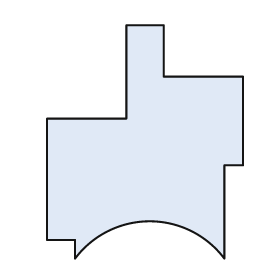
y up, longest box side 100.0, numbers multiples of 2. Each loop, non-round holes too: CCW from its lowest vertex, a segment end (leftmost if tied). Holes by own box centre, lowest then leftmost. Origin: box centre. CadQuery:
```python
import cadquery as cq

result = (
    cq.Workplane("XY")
    .moveTo(-30.0, -50.0)
    .threePointArc((2.0, -34.0), (34.0, -50.0))
    .lineTo(34.0, -10.0)
    .lineTo(42.0, -10.0)
    .lineTo(42.0, 28.0)
    .lineTo(8.0, 28.0)
    .lineTo(8.0, 50.0)
    .lineTo(-8.0, 50.0)
    .lineTo(-8.0, 10.0)
    .lineTo(-42.0, 10.0)
    .lineTo(-42.0, -42.0)
    .lineTo(-30.0, -42.0)
    .close()
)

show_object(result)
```